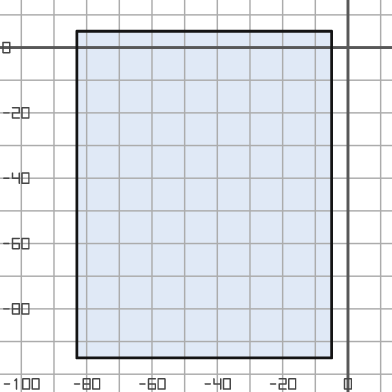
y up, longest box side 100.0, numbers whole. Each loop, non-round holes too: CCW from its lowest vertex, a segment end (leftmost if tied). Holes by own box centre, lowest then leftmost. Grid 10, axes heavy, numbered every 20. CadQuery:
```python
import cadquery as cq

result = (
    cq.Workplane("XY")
    .moveTo(-83.0, -95.0)
    .lineTo(-5.0, -95.0)
    .lineTo(-5.0, 5.0)
    .lineTo(-83.0, 5.0)
    .close()
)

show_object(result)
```